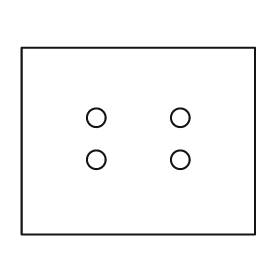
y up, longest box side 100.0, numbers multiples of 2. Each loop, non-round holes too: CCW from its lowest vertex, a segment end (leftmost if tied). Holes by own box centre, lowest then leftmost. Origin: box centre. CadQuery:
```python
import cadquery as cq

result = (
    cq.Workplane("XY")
    .moveTo(-50.0, -40.0)
    .lineTo(50.0, -40.0)
    .lineTo(50.0, 40.0)
    .lineTo(-50.0, 40.0)
    .close()
    .moveTo(-18.0, -8.0)
    .circle(4.0)
    .moveTo(18.0, -8.0)
    .circle(4.0)
    .moveTo(-18.0, 10.0)
    .circle(4.0)
    .moveTo(18.0, 10.0)
    .circle(4.0)
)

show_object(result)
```